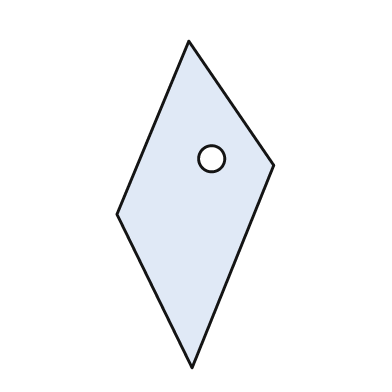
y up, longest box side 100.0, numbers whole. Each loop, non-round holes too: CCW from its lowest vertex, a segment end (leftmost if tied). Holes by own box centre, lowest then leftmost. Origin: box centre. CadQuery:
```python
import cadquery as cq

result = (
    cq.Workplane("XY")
    .moveTo(-1.0, -50.0)
    .lineTo(24.0, 12.0)
    .lineTo(-2.0, 50.0)
    .lineTo(-24.0, -3.0)
    .close()
    .moveTo(5.0, 14.0)
    .circle(4.0)
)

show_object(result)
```